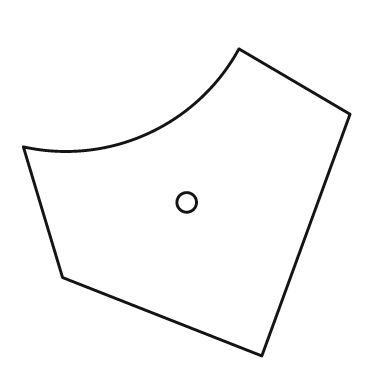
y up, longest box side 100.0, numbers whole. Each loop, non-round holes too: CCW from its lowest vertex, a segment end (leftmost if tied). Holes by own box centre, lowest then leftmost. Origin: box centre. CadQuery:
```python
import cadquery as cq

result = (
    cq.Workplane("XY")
    .moveTo(23.0, -47.0)
    .lineTo(50.0, 27.0)
    .lineTo(16.0, 47.0)
    .threePointArc((-12.0, 21.0), (-50.0, 17.0))
    .lineTo(-38.0, -23.0)
    .close()
    .moveTo(0.0, 0.0)
    .circle(3.0)
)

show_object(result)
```